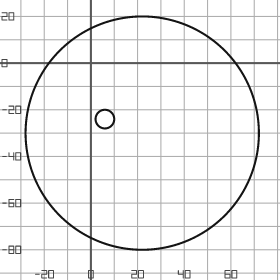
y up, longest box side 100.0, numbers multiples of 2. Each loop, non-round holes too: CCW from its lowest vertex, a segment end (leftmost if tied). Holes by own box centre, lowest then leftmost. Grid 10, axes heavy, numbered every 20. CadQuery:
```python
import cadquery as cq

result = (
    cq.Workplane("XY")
    .moveTo(22.0, -30.0)
    .circle(50.0)
    .moveTo(6.0, -24.0)
    .circle(4.0)
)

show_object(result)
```